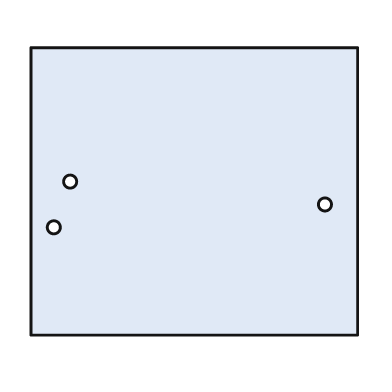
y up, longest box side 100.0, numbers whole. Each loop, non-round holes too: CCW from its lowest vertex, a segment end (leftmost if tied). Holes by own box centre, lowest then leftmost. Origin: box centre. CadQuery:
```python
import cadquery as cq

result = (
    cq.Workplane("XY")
    .moveTo(-50.0, -44.0)
    .lineTo(50.0, -44.0)
    .lineTo(50.0, 44.0)
    .lineTo(-50.0, 44.0)
    .close()
    .moveTo(-43.0, -11.0)
    .circle(2.0)
    .moveTo(40.0, -4.0)
    .circle(2.0)
    .moveTo(-38.0, 3.0)
    .circle(2.0)
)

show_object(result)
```